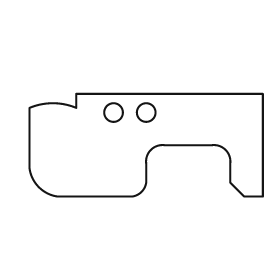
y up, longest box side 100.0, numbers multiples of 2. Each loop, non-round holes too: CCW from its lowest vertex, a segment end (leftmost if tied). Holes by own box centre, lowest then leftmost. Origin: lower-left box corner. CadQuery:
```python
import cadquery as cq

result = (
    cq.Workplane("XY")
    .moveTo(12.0, 0.0)
    .lineTo(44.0, 0.0)
    .threePointArc((48.0, 2.0), (50.0, 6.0))
    .lineTo(50.0, 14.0)
    .threePointArc((52.0, 20.0), (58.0, 22.0))
    .lineTo(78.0, 22.0)
    .threePointArc((84.0, 20.0), (86.0, 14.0))
    .lineTo(86.0, 6.0)
    .lineTo(92.0, 0.0)
    .lineTo(100.0, 0.0)
    .lineTo(100.0, 44.0)
    .lineTo(20.0, 44.0)
    .lineTo(20.0, 38.0)
    .threePointArc((10.0, 40.0), (0.0, 38.0))
    .lineTo(0.0, 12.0)
    .threePointArc((4.0, 4.0), (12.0, 0.0))
    .close()
    .moveTo(36.0, 36.0)
    .circle(4.0)
    .moveTo(50.0, 36.0)
    .circle(4.0)
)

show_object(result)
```